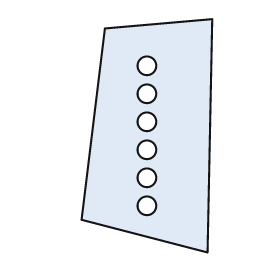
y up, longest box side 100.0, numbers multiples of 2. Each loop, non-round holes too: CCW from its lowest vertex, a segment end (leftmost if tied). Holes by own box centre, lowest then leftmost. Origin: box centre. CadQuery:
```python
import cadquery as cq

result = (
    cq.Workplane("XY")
    .moveTo(26.0, -50.0)
    .lineTo(28.0, 50.0)
    .lineTo(-18.0, 46.0)
    .lineTo(-28.0, -36.0)
    .close()
    .moveTo(0.0, -30.0)
    .circle(4.0)
    .moveTo(0.0, -18.0)
    .circle(4.0)
    .moveTo(0.0, -6.0)
    .circle(4.0)
    .moveTo(0.0, 6.0)
    .circle(4.0)
    .moveTo(0.0, 18.0)
    .circle(4.0)
    .moveTo(0.0, 30.0)
    .circle(4.0)
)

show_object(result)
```